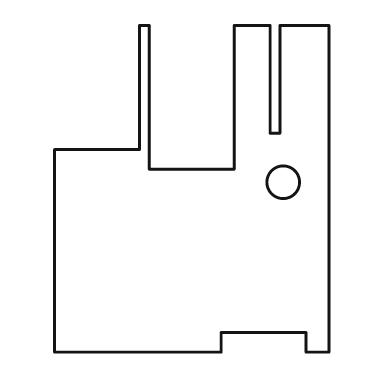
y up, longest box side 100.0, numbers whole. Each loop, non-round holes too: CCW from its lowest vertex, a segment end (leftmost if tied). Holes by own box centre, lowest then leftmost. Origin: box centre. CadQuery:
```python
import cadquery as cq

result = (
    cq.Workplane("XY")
    .moveTo(-42.0, -50.0)
    .lineTo(9.0, -50.0)
    .lineTo(9.0, -44.0)
    .lineTo(35.0, -44.0)
    .lineTo(35.0, -50.0)
    .lineTo(42.0, -50.0)
    .lineTo(42.0, 50.0)
    .lineTo(27.0, 50.0)
    .lineTo(27.0, 17.0)
    .lineTo(24.0, 17.0)
    .lineTo(24.0, 50.0)
    .lineTo(13.0, 50.0)
    .lineTo(13.0, 6.0)
    .lineTo(-13.0, 6.0)
    .lineTo(-13.0, 50.0)
    .lineTo(-16.0, 50.0)
    .lineTo(-16.0, 12.0)
    .lineTo(-42.0, 12.0)
    .close()
    .moveTo(28.0, 2.0)
    .circle(5.0)
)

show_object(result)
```